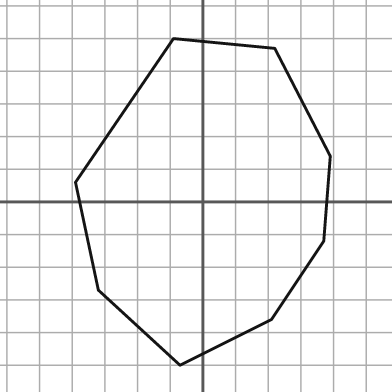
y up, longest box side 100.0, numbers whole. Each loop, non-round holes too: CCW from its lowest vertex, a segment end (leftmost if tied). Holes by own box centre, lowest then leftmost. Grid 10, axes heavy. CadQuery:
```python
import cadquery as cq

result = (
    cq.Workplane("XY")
    .moveTo(-7.0, -50.0)
    .lineTo(21.0, -36.0)
    .lineTo(37.0, -12.0)
    .lineTo(39.0, 14.0)
    .lineTo(22.0, 47.0)
    .lineTo(-9.0, 50.0)
    .lineTo(-39.0, 6.0)
    .lineTo(-32.0, -27.0)
    .close()
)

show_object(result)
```